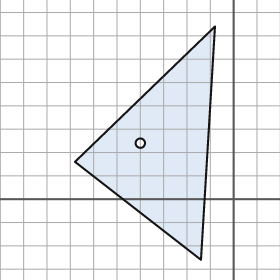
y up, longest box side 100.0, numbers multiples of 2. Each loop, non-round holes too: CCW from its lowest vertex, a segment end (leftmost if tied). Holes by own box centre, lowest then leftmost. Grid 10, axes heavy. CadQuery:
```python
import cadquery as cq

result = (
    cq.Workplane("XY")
    .moveTo(-14.0, -26.0)
    .lineTo(-8.0, 74.0)
    .lineTo(-68.0, 16.0)
    .close()
    .moveTo(-40.0, 24.0)
    .circle(2.0)
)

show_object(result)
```